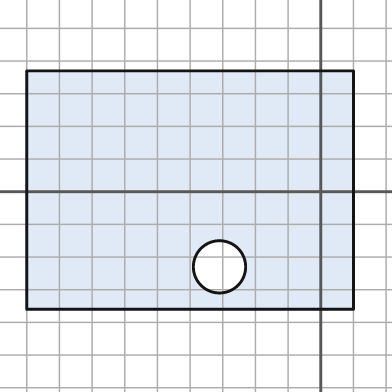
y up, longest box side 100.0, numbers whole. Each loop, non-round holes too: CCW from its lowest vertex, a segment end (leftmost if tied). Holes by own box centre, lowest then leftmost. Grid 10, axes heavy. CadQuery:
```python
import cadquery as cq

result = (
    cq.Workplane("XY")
    .moveTo(-90.0, -36.0)
    .lineTo(10.0, -36.0)
    .lineTo(10.0, 37.0)
    .lineTo(-90.0, 37.0)
    .close()
    .moveTo(-31.0, -23.0)
    .circle(8.0)
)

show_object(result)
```